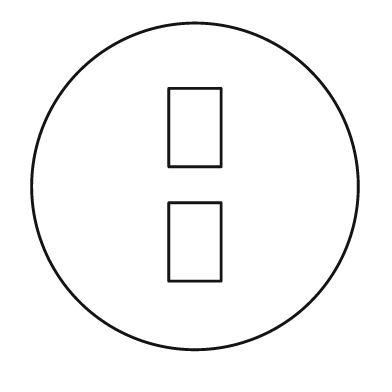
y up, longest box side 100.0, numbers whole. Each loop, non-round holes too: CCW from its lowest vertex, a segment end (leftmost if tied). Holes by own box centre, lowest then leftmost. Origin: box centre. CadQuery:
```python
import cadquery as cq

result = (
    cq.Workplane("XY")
    .moveTo(0.0, 0.0)
    .circle(50.0)
    .moveTo(-8.0, -29.0)
    .lineTo(8.0, -29.0)
    .lineTo(8.0, -5.0)
    .lineTo(-8.0, -5.0)
    .close()
    .moveTo(-8.0, 6.0)
    .lineTo(8.0, 6.0)
    .lineTo(8.0, 30.0)
    .lineTo(-8.0, 30.0)
    .close()
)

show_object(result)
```